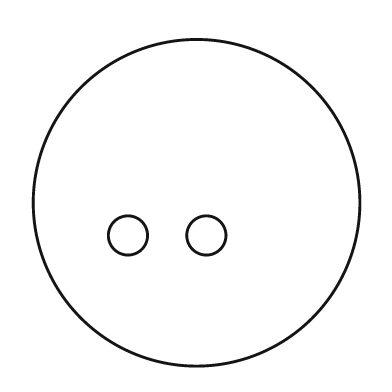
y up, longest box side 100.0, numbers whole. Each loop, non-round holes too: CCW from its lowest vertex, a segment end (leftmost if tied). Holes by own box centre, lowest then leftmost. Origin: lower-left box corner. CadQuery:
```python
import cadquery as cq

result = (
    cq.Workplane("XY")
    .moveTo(50.0, 50.0)
    .circle(50.0)
    .moveTo(29.0, 40.0)
    .circle(6.0)
    .moveTo(53.0, 40.0)
    .circle(6.0)
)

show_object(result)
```